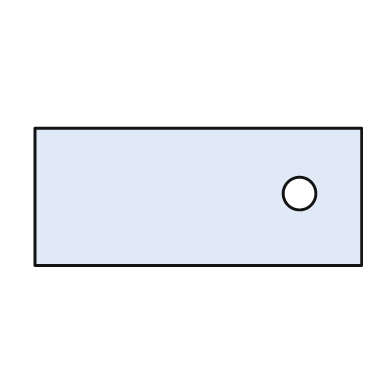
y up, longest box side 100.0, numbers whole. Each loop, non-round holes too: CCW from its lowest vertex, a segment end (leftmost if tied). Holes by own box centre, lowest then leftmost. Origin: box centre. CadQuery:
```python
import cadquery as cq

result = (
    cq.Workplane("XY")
    .moveTo(-50.0, -21.0)
    .lineTo(50.0, -21.0)
    .lineTo(50.0, 21.0)
    .lineTo(-50.0, 21.0)
    .close()
    .moveTo(31.0, 1.0)
    .circle(5.0)
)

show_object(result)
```